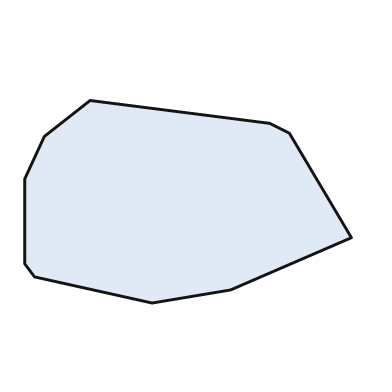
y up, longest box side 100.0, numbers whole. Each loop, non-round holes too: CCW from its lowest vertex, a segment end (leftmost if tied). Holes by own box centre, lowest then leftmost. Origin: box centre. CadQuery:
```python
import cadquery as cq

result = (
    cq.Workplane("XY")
    .moveTo(-11.0, -31.0)
    .lineTo(13.0, -27.0)
    .lineTo(50.0, -11.0)
    .lineTo(31.0, 21.0)
    .lineTo(25.0, 24.0)
    .lineTo(-30.0, 31.0)
    .lineTo(-44.0, 20.0)
    .lineTo(-50.0, 7.0)
    .lineTo(-50.0, -19.0)
    .lineTo(-47.0, -23.0)
    .close()
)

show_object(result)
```